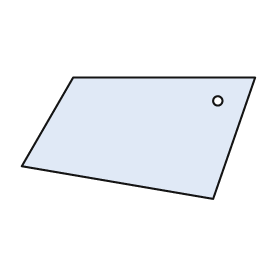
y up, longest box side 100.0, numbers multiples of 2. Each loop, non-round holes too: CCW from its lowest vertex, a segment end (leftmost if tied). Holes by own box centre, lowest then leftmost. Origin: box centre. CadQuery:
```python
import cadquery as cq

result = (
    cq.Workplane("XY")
    .moveTo(32.0, -26.0)
    .lineTo(50.0, 26.0)
    .lineTo(-28.0, 26.0)
    .lineTo(-50.0, -12.0)
    .close()
    .moveTo(34.0, 16.0)
    .circle(2.0)
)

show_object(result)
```